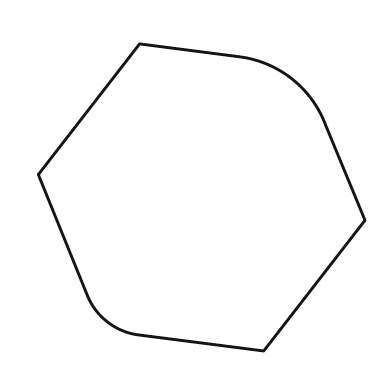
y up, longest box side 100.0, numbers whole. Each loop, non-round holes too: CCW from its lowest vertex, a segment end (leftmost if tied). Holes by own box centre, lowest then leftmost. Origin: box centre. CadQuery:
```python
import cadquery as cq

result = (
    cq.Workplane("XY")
    .moveTo(19.0, -47.0)
    .lineTo(50.0, -7.0)
    .lineTo(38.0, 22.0)
    .threePointArc((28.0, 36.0), (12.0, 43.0))
    .lineTo(-19.0, 47.0)
    .lineTo(-50.0, 7.0)
    .lineTo(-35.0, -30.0)
    .threePointArc((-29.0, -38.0), (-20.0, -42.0))
    .close()
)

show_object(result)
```